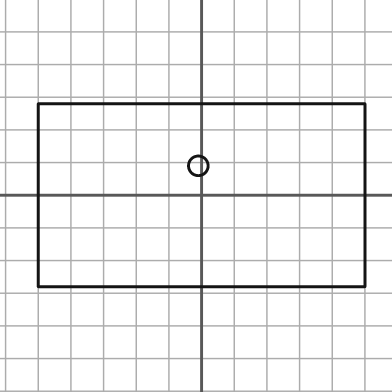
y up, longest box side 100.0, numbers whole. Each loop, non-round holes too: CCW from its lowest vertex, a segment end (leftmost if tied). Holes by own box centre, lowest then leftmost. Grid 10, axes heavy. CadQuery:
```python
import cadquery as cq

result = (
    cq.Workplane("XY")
    .moveTo(-50.0, -28.0)
    .lineTo(50.0, -28.0)
    .lineTo(50.0, 28.0)
    .lineTo(-50.0, 28.0)
    .close()
    .moveTo(-1.0, 9.0)
    .circle(3.0)
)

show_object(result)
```